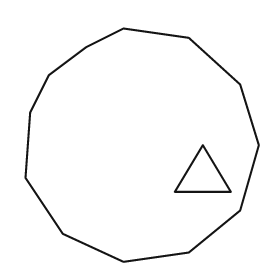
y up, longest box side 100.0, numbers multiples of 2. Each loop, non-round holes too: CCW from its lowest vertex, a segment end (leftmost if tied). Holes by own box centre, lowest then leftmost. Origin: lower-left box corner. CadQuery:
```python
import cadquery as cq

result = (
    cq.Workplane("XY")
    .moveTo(42.0, 0.0)
    .lineTo(70.0, 4.0)
    .lineTo(92.0, 22.0)
    .lineTo(100.0, 50.0)
    .lineTo(92.0, 76.0)
    .lineTo(70.0, 96.0)
    .lineTo(42.0, 100.0)
    .lineTo(26.0, 92.0)
    .lineTo(10.0, 80.0)
    .lineTo(2.0, 64.0)
    .lineTo(0.0, 36.0)
    .lineTo(16.0, 12.0)
    .close()
    .moveTo(64.0, 30.0)
    .lineTo(88.0, 30.0)
    .lineTo(76.0, 50.0)
    .close()
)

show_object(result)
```